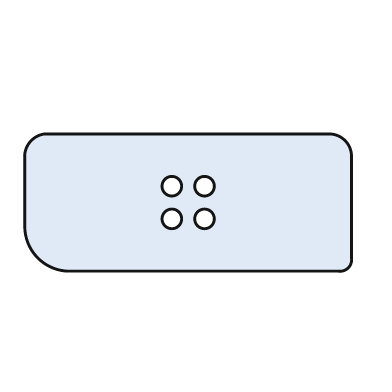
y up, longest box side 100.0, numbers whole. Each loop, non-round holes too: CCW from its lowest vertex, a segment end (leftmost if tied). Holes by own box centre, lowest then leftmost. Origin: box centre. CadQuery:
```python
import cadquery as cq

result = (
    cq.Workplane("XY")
    .moveTo(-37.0, -21.0)
    .lineTo(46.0, -21.0)
    .threePointArc((49.0, -20.0), (50.0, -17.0))
    .lineTo(50.0, 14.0)
    .threePointArc((48.0, 19.0), (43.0, 21.0))
    .lineTo(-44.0, 21.0)
    .threePointArc((-48.0, 19.0), (-50.0, 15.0))
    .lineTo(-50.0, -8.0)
    .threePointArc((-46.0, -17.0), (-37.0, -21.0))
    .close()
    .moveTo(-5.0, -5.0)
    .circle(3.0)
    .moveTo(5.0, -5.0)
    .circle(3.0)
    .moveTo(-5.0, 5.0)
    .circle(3.0)
    .moveTo(5.0, 5.0)
    .circle(3.0)
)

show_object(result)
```